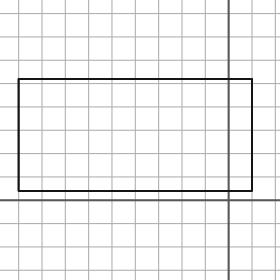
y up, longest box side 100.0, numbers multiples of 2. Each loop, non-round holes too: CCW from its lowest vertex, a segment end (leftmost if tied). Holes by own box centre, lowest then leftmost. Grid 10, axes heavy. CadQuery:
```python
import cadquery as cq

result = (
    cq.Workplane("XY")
    .moveTo(-90.0, 4.0)
    .lineTo(10.0, 4.0)
    .lineTo(10.0, 52.0)
    .lineTo(-90.0, 52.0)
    .close()
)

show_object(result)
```